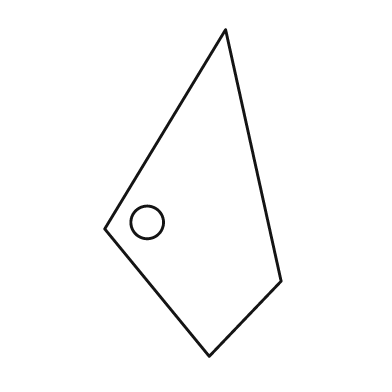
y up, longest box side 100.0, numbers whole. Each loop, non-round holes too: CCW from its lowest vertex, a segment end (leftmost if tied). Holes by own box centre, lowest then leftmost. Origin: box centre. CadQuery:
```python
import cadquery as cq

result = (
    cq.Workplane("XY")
    .moveTo(5.0, -50.0)
    .lineTo(27.0, -27.0)
    .lineTo(10.0, 50.0)
    .lineTo(-27.0, -11.0)
    .close()
    .moveTo(-14.0, -9.0)
    .circle(5.0)
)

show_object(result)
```